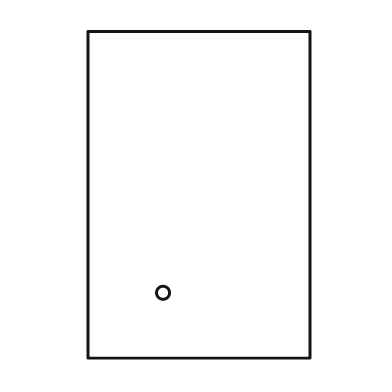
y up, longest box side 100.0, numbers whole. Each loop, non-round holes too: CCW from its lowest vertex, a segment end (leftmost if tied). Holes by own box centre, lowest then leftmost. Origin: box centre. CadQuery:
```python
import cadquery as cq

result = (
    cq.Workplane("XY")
    .moveTo(-34.0, -50.0)
    .lineTo(34.0, -50.0)
    .lineTo(34.0, 50.0)
    .lineTo(-34.0, 50.0)
    .close()
    .moveTo(-11.0, -30.0)
    .circle(2.0)
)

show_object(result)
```